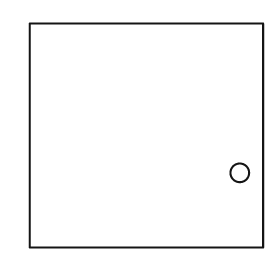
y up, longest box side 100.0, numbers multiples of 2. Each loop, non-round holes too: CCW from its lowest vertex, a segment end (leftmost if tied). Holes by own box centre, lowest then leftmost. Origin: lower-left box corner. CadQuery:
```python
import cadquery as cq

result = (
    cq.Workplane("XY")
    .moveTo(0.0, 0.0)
    .lineTo(100.0, 0.0)
    .lineTo(100.0, 96.0)
    .lineTo(0.0, 96.0)
    .close()
    .moveTo(90.0, 32.0)
    .circle(4.0)
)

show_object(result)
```